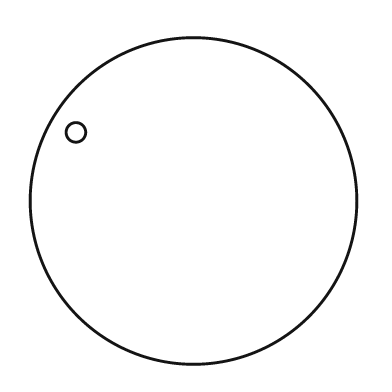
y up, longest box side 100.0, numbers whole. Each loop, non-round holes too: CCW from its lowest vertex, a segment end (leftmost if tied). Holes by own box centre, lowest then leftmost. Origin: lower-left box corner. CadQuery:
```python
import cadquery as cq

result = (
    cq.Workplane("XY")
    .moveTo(50.0, 50.0)
    .circle(50.0)
    .moveTo(14.0, 71.0)
    .circle(3.0)
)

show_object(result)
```